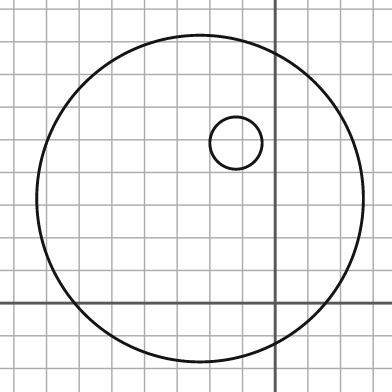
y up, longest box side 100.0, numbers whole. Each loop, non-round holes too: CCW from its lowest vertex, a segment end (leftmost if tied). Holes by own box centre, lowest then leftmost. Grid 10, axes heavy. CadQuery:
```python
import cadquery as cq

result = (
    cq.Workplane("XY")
    .moveTo(-23.0, 32.0)
    .circle(50.0)
    .moveTo(-12.0, 49.0)
    .circle(8.0)
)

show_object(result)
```